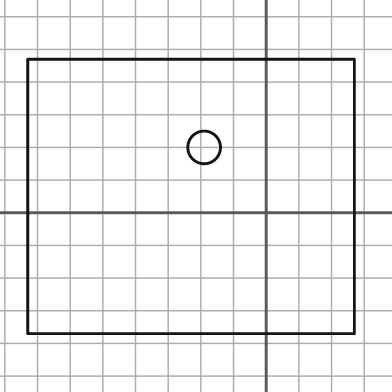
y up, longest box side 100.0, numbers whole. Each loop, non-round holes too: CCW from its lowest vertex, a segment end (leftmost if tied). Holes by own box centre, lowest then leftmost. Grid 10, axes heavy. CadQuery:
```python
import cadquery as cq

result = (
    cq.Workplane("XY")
    .moveTo(-73.0, -37.0)
    .lineTo(27.0, -37.0)
    .lineTo(27.0, 47.0)
    .lineTo(-73.0, 47.0)
    .close()
    .moveTo(-19.0, 20.0)
    .circle(5.0)
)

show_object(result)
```